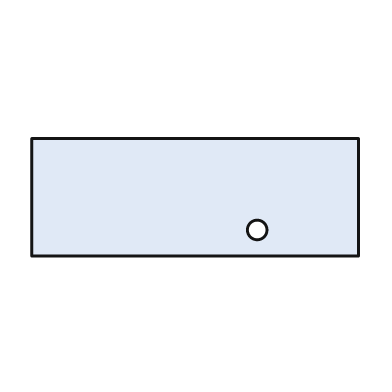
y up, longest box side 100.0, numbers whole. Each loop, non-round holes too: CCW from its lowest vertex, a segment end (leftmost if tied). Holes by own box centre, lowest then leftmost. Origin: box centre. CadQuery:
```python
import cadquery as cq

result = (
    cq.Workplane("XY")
    .moveTo(-50.0, -18.0)
    .lineTo(50.0, -18.0)
    .lineTo(50.0, 18.0)
    .lineTo(-50.0, 18.0)
    .close()
    .moveTo(19.0, -10.0)
    .circle(3.0)
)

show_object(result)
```